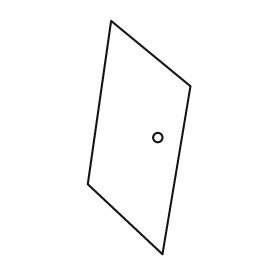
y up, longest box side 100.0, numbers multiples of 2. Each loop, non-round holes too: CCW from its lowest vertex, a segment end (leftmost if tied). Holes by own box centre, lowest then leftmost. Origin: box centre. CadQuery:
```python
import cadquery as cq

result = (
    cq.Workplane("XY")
    .moveTo(10.0, -50.0)
    .lineTo(22.0, 22.0)
    .lineTo(-12.0, 50.0)
    .lineTo(-22.0, -20.0)
    .close()
    .moveTo(8.0, 0.0)
    .circle(2.0)
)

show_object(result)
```